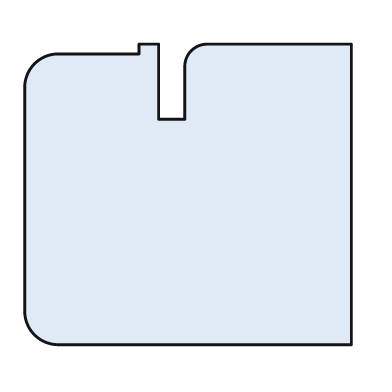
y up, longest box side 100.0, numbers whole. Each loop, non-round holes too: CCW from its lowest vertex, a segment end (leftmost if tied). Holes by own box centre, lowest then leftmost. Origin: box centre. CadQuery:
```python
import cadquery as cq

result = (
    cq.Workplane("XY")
    .moveTo(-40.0, -46.0)
    .lineTo(50.0, -46.0)
    .lineTo(50.0, 46.0)
    .lineTo(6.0, 46.0)
    .threePointArc((1.0, 44.0), (-1.0, 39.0))
    .lineTo(-1.0, 23.0)
    .lineTo(-9.0, 23.0)
    .lineTo(-9.0, 46.0)
    .lineTo(-15.0, 46.0)
    .lineTo(-15.0, 43.0)
    .lineTo(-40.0, 43.0)
    .threePointArc((-47.0, 40.0), (-50.0, 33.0))
    .lineTo(-50.0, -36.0)
    .threePointArc((-47.0, -43.0), (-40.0, -46.0))
    .close()
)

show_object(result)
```